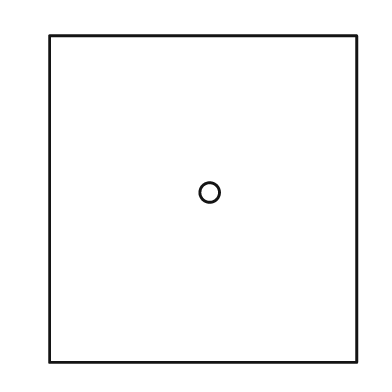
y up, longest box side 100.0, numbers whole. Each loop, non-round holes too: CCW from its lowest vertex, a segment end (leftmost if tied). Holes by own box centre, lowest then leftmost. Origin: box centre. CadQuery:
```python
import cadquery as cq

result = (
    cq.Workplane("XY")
    .moveTo(-47.0, -50.0)
    .lineTo(47.0, -50.0)
    .lineTo(47.0, 50.0)
    .lineTo(-47.0, 50.0)
    .close()
    .moveTo(2.0, 2.0)
    .circle(3.0)
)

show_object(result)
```